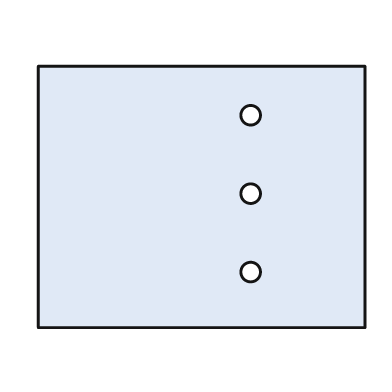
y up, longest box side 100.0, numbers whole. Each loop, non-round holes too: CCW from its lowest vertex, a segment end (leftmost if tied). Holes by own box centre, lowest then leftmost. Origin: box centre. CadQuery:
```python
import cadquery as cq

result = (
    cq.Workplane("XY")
    .moveTo(-50.0, -40.0)
    .lineTo(50.0, -40.0)
    .lineTo(50.0, 40.0)
    .lineTo(-50.0, 40.0)
    .close()
    .moveTo(15.0, -23.0)
    .circle(3.0)
    .moveTo(15.0, 1.0)
    .circle(3.0)
    .moveTo(15.0, 25.0)
    .circle(3.0)
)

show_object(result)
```